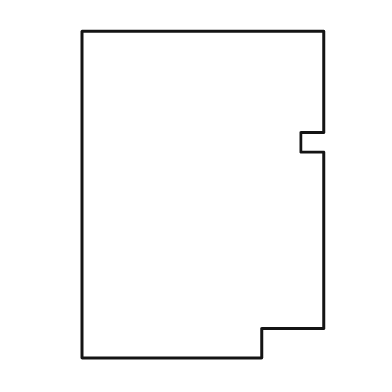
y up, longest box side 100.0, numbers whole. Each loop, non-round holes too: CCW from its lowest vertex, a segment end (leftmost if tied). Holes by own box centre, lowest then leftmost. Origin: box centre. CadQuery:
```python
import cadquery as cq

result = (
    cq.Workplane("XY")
    .moveTo(-37.0, -50.0)
    .lineTo(18.0, -50.0)
    .lineTo(18.0, -41.0)
    .lineTo(37.0, -41.0)
    .lineTo(37.0, 13.0)
    .lineTo(30.0, 13.0)
    .lineTo(30.0, 19.0)
    .lineTo(37.0, 19.0)
    .lineTo(37.0, 50.0)
    .lineTo(-37.0, 50.0)
    .close()
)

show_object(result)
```